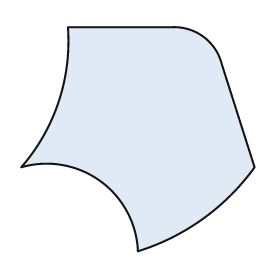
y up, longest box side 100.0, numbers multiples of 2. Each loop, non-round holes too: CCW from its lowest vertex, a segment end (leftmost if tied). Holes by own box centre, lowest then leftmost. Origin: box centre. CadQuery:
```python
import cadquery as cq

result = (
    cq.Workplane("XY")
    .moveTo(0.0, -48.0)
    .threePointArc((28.0, -34.0), (50.0, -12.0))
    .lineTo(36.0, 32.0)
    .threePointArc((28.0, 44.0), (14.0, 48.0))
    .lineTo(-30.0, 48.0)
    .threePointArc((-34.0, 16.0), (-50.0, -12.0))
    .threePointArc((-16.0, -18.0), (0.0, -48.0))
    .close()
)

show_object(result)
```